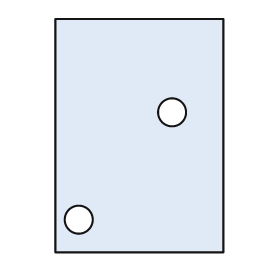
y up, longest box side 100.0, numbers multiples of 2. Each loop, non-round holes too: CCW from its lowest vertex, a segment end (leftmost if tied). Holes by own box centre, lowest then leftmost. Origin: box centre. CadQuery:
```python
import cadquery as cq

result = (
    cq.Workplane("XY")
    .moveTo(-36.0, -50.0)
    .lineTo(36.0, -50.0)
    .lineTo(36.0, 50.0)
    .lineTo(-36.0, 50.0)
    .close()
    .moveTo(-26.0, -36.0)
    .circle(6.0)
    .moveTo(14.0, 10.0)
    .circle(6.0)
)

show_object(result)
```